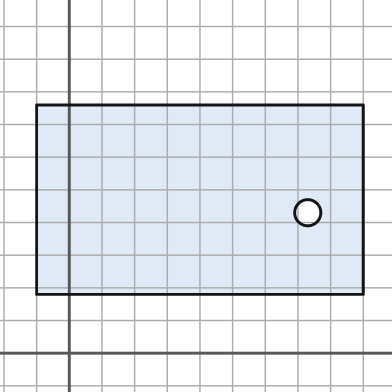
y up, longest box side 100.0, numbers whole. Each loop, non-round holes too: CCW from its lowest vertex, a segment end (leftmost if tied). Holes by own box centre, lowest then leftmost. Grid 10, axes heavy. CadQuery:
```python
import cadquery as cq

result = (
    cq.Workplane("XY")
    .moveTo(-10.0, 18.0)
    .lineTo(90.0, 18.0)
    .lineTo(90.0, 76.0)
    .lineTo(-10.0, 76.0)
    .close()
    .moveTo(73.0, 43.0)
    .circle(4.0)
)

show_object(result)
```